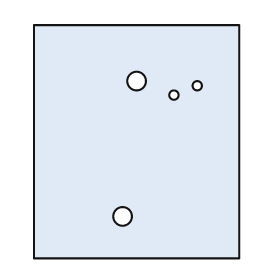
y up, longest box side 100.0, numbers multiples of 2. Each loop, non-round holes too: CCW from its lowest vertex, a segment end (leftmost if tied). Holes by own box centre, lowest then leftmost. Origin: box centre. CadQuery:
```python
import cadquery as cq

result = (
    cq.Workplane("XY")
    .moveTo(-44.0, -50.0)
    .lineTo(44.0, -50.0)
    .lineTo(44.0, 50.0)
    .lineTo(-44.0, 50.0)
    .close()
    .moveTo(-6.0, -32.0)
    .circle(4.0)
    .moveTo(16.0, 20.0)
    .circle(2.0)
    .moveTo(26.0, 24.0)
    .circle(2.0)
    .moveTo(0.0, 26.0)
    .circle(4.0)
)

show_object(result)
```